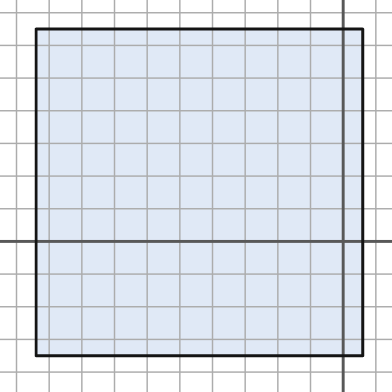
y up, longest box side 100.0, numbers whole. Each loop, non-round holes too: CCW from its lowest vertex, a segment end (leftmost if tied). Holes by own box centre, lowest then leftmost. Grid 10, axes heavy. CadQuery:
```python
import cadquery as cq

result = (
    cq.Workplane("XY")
    .moveTo(-94.0, -35.0)
    .lineTo(6.0, -35.0)
    .lineTo(6.0, 65.0)
    .lineTo(-94.0, 65.0)
    .close()
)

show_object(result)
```